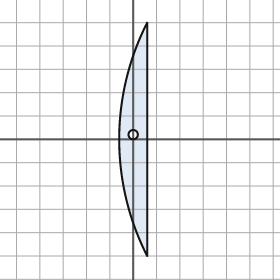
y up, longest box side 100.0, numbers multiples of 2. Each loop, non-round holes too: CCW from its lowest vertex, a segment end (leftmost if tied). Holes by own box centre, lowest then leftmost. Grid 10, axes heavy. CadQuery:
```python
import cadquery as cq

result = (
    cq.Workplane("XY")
    .moveTo(6.0, -50.0)
    .lineTo(6.0, 50.0)
    .threePointArc((-6.0, 0.0), (6.0, -50.0))
    .close()
    .moveTo(0.0, 2.0)
    .circle(2.0)
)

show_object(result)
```